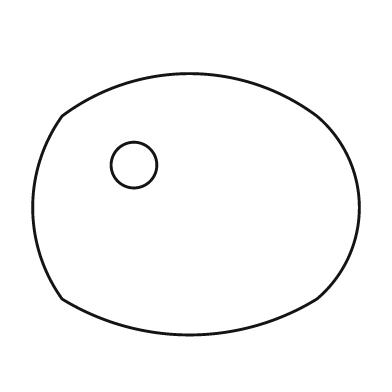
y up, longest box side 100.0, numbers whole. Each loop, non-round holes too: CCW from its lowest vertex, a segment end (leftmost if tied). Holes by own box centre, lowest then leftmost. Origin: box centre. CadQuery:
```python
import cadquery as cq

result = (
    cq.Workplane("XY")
    .moveTo(-41.0, -29.0)
    .threePointArc((-2.0, -40.0), (37.0, -29.0))
    .threePointArc((50.0, -1.0), (37.0, 27.0))
    .threePointArc((-2.0, 40.0), (-41.0, 27.0))
    .threePointArc((-50.0, -1.0), (-41.0, -29.0))
    .close()
    .moveTo(-19.0, 12.0)
    .circle(7.0)
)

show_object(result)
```